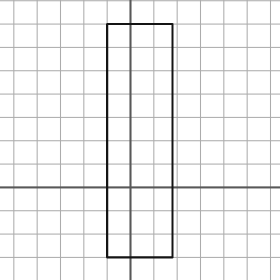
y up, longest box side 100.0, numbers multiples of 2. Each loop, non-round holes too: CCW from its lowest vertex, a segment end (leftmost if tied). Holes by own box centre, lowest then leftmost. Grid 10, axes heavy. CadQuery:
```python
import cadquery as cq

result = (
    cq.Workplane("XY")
    .moveTo(-10.0, -30.0)
    .lineTo(18.0, -30.0)
    .lineTo(18.0, 70.0)
    .lineTo(-10.0, 70.0)
    .close()
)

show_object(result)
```